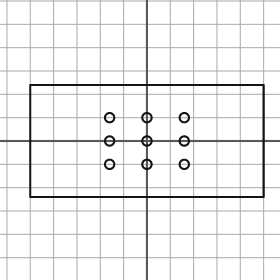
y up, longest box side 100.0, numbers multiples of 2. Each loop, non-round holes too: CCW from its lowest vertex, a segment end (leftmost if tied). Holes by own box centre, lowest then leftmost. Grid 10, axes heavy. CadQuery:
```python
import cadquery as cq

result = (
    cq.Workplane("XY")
    .moveTo(-50.0, -24.0)
    .lineTo(50.0, -24.0)
    .lineTo(50.0, 24.0)
    .lineTo(-50.0, 24.0)
    .close()
    .moveTo(-16.0, -10.0)
    .circle(2.0)
    .moveTo(0.0, -10.0)
    .circle(2.0)
    .moveTo(16.0, -10.0)
    .circle(2.0)
    .moveTo(-16.0, 0.0)
    .circle(2.0)
    .moveTo(0.0, 0.0)
    .circle(2.0)
    .moveTo(16.0, 0.0)
    .circle(2.0)
    .moveTo(-16.0, 10.0)
    .circle(2.0)
    .moveTo(0.0, 10.0)
    .circle(2.0)
    .moveTo(16.0, 10.0)
    .circle(2.0)
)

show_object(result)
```